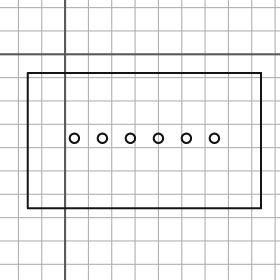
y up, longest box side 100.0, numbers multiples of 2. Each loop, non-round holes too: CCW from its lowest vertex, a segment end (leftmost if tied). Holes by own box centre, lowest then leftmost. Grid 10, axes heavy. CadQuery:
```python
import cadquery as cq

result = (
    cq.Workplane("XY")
    .moveTo(-16.0, -66.0)
    .lineTo(84.0, -66.0)
    .lineTo(84.0, -8.0)
    .lineTo(-16.0, -8.0)
    .close()
    .moveTo(4.0, -36.0)
    .circle(2.0)
    .moveTo(16.0, -36.0)
    .circle(2.0)
    .moveTo(28.0, -36.0)
    .circle(2.0)
    .moveTo(40.0, -36.0)
    .circle(2.0)
    .moveTo(52.0, -36.0)
    .circle(2.0)
    .moveTo(64.0, -36.0)
    .circle(2.0)
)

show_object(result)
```